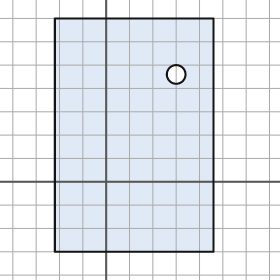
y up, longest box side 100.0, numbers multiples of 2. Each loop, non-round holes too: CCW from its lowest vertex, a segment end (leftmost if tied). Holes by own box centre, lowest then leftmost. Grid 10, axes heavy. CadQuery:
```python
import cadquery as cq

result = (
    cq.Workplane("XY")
    .moveTo(-22.0, -30.0)
    .lineTo(46.0, -30.0)
    .lineTo(46.0, 70.0)
    .lineTo(-22.0, 70.0)
    .close()
    .moveTo(30.0, 46.0)
    .circle(4.0)
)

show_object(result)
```